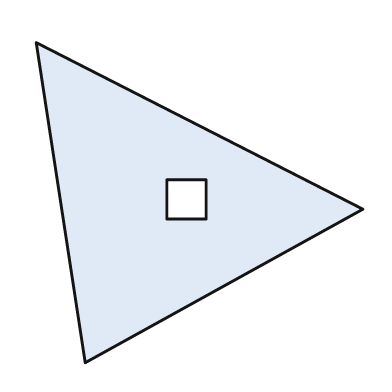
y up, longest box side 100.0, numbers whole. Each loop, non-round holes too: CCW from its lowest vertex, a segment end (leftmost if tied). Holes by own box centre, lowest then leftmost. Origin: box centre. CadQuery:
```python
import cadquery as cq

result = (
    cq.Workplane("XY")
    .moveTo(-35.0, -49.0)
    .lineTo(50.0, -2.0)
    .lineTo(-50.0, 49.0)
    .close()
    .moveTo(-10.0, -5.0)
    .lineTo(2.0, -5.0)
    .lineTo(2.0, 7.0)
    .lineTo(-10.0, 7.0)
    .close()
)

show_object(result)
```